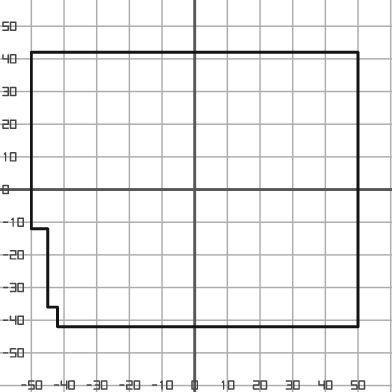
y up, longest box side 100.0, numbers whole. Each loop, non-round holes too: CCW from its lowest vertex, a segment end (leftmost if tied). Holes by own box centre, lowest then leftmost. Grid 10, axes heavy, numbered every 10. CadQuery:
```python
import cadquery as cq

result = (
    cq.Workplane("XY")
    .moveTo(-42.0, -42.0)
    .lineTo(50.0, -42.0)
    .lineTo(50.0, 42.0)
    .lineTo(-50.0, 42.0)
    .lineTo(-50.0, -12.0)
    .lineTo(-45.0, -12.0)
    .lineTo(-45.0, -36.0)
    .lineTo(-42.0, -36.0)
    .close()
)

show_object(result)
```